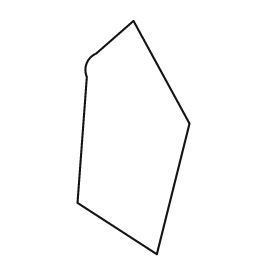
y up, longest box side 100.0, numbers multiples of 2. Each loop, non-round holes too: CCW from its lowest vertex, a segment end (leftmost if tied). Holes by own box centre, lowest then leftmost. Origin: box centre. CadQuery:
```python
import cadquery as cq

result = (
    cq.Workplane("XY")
    .moveTo(10.0, -50.0)
    .lineTo(24.0, 6.0)
    .lineTo(0.0, 50.0)
    .lineTo(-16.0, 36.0)
    .threePointArc((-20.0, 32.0), (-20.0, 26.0))
    .lineTo(-24.0, -28.0)
    .close()
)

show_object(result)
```